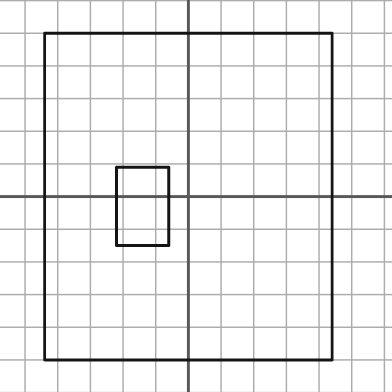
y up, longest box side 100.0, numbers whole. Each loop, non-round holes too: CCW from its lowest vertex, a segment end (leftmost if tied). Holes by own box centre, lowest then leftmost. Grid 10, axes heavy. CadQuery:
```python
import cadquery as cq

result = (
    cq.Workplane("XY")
    .moveTo(-44.0, -50.0)
    .lineTo(44.0, -50.0)
    .lineTo(44.0, 50.0)
    .lineTo(-44.0, 50.0)
    .close()
    .moveTo(-22.0, -15.0)
    .lineTo(-6.0, -15.0)
    .lineTo(-6.0, 9.0)
    .lineTo(-22.0, 9.0)
    .close()
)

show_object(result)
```